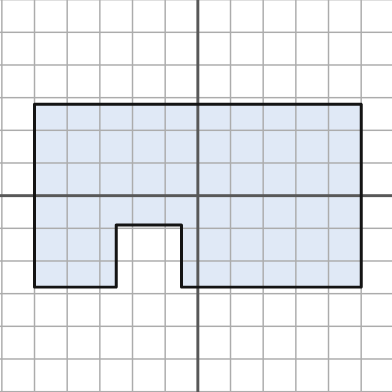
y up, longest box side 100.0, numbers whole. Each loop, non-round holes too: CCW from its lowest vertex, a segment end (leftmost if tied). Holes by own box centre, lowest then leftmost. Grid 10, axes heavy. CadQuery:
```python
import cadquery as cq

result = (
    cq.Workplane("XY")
    .moveTo(-50.0, -28.0)
    .lineTo(-25.0, -28.0)
    .lineTo(-25.0, -9.0)
    .lineTo(-5.0, -9.0)
    .lineTo(-5.0, -28.0)
    .lineTo(50.0, -28.0)
    .lineTo(50.0, 28.0)
    .lineTo(-50.0, 28.0)
    .close()
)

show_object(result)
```